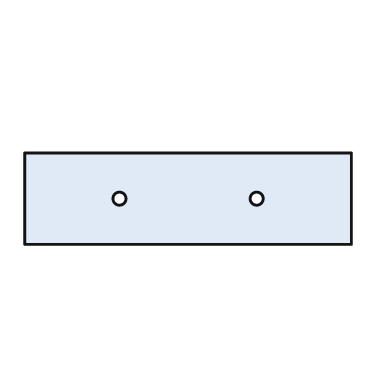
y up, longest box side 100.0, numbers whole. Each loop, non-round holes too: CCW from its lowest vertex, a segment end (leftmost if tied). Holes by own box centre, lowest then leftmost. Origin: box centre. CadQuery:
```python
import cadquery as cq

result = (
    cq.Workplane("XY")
    .moveTo(-50.0, -14.0)
    .lineTo(50.0, -14.0)
    .lineTo(50.0, 14.0)
    .lineTo(-50.0, 14.0)
    .close()
    .moveTo(-21.0, 0.0)
    .circle(2.0)
    .moveTo(21.0, 0.0)
    .circle(2.0)
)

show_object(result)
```